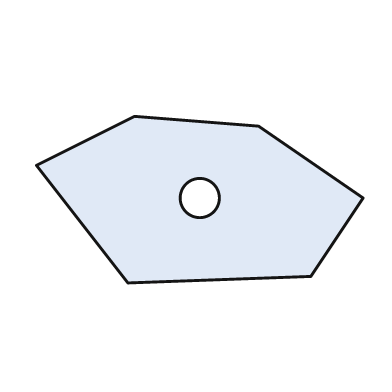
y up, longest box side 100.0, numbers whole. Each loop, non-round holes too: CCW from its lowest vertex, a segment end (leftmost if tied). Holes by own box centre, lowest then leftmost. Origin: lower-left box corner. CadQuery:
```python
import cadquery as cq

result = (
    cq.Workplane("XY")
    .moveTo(28.0, 0.0)
    .lineTo(84.0, 2.0)
    .lineTo(100.0, 26.0)
    .lineTo(68.0, 48.0)
    .lineTo(30.0, 51.0)
    .lineTo(0.0, 36.0)
    .close()
    .moveTo(50.0, 26.0)
    .circle(6.0)
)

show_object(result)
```